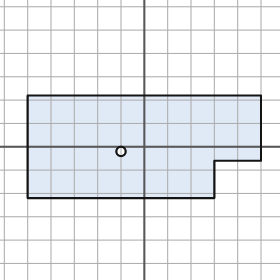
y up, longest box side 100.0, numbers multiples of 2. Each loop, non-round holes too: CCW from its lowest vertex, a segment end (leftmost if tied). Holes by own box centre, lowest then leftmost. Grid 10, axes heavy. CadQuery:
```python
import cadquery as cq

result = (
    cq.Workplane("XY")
    .moveTo(-50.0, -22.0)
    .lineTo(30.0, -22.0)
    .lineTo(30.0, -6.0)
    .lineTo(50.0, -6.0)
    .lineTo(50.0, 22.0)
    .lineTo(-50.0, 22.0)
    .close()
    .moveTo(-10.0, -2.0)
    .circle(2.0)
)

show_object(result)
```